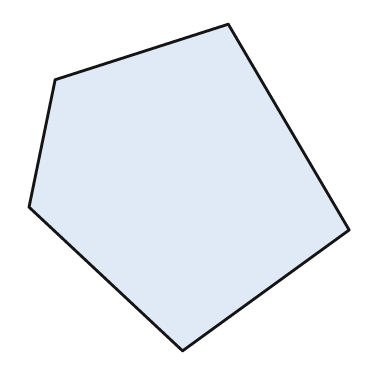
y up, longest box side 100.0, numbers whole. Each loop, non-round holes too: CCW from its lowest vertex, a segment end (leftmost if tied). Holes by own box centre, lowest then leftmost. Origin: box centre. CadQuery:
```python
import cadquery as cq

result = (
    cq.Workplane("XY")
    .moveTo(-2.0, -50.0)
    .lineTo(49.0, -13.0)
    .lineTo(12.0, 50.0)
    .lineTo(-41.0, 33.0)
    .lineTo(-49.0, -6.0)
    .close()
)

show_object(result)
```